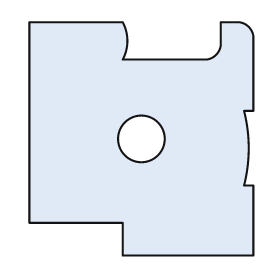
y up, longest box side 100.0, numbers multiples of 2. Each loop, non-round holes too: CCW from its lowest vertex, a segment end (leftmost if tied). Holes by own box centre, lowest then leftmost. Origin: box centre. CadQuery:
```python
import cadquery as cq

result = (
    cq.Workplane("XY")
    .moveTo(-8.0, -50.0)
    .lineTo(48.0, -50.0)
    .lineTo(48.0, -20.0)
    .lineTo(44.0, -20.0)
    .threePointArc((46.0, -4.0), (44.0, 12.0))
    .lineTo(48.0, 12.0)
    .lineTo(48.0, 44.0)
    .threePointArc((46.0, 48.0), (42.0, 50.0))
    .lineTo(34.0, 50.0)
    .lineTo(34.0, 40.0)
    .threePointArc((32.0, 36.0), (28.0, 34.0))
    .lineTo(-8.0, 34.0)
    .threePointArc((-6.0, 42.0), (-8.0, 50.0))
    .lineTo(-48.0, 50.0)
    .lineTo(-48.0, -36.0)
    .lineTo(-8.0, -36.0)
    .close()
    .moveTo(0.0, 0.0)
    .circle(10.0)
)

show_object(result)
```